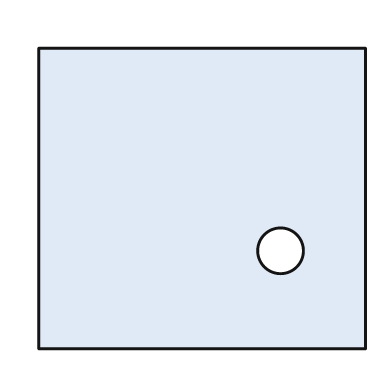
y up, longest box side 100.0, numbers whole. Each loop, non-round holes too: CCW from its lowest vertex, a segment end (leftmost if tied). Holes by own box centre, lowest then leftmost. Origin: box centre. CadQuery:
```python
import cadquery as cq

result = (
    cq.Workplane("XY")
    .moveTo(-50.0, -46.0)
    .lineTo(50.0, -46.0)
    .lineTo(50.0, 46.0)
    .lineTo(-50.0, 46.0)
    .close()
    .moveTo(24.0, -16.0)
    .circle(7.0)
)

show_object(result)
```